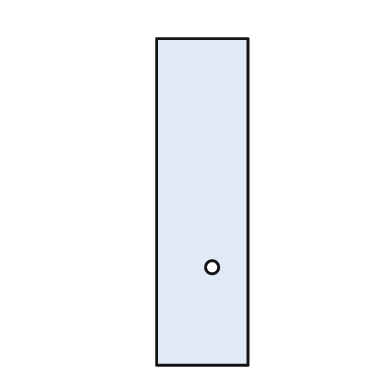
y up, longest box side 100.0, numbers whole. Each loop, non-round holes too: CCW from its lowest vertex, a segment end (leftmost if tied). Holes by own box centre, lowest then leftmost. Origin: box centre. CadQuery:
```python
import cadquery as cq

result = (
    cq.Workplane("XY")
    .moveTo(-14.0, -50.0)
    .lineTo(14.0, -50.0)
    .lineTo(14.0, 50.0)
    .lineTo(-14.0, 50.0)
    .close()
    .moveTo(3.0, -20.0)
    .circle(2.0)
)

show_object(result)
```